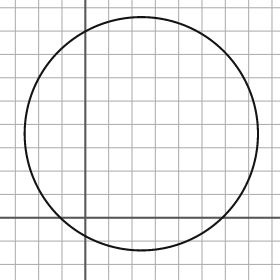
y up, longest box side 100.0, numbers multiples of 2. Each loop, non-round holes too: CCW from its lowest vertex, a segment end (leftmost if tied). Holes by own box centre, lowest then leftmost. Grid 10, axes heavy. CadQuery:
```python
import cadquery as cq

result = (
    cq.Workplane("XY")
    .moveTo(24.0, 36.0)
    .circle(50.0)
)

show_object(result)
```